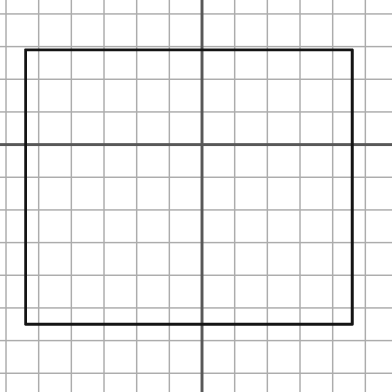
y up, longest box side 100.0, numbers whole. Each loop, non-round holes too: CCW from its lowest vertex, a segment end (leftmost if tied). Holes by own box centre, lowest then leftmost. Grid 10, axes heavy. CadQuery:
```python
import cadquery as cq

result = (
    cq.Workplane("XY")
    .moveTo(-54.0, -55.0)
    .lineTo(46.0, -55.0)
    .lineTo(46.0, 29.0)
    .lineTo(-54.0, 29.0)
    .close()
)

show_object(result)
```